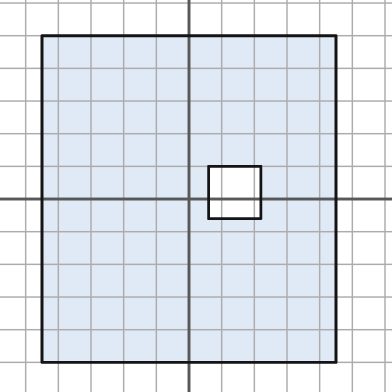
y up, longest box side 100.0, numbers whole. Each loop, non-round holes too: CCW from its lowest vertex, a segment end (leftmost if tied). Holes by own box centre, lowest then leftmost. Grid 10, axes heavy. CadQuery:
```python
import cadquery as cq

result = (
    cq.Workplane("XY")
    .moveTo(-45.0, -50.0)
    .lineTo(45.0, -50.0)
    .lineTo(45.0, 50.0)
    .lineTo(-45.0, 50.0)
    .close()
    .moveTo(6.0, -6.0)
    .lineTo(22.0, -6.0)
    .lineTo(22.0, 10.0)
    .lineTo(6.0, 10.0)
    .close()
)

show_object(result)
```